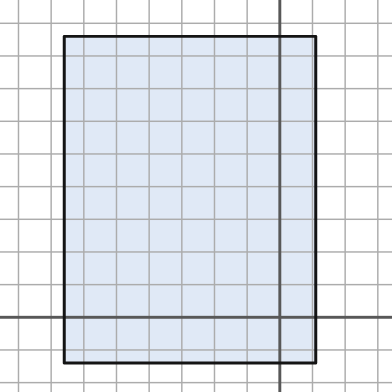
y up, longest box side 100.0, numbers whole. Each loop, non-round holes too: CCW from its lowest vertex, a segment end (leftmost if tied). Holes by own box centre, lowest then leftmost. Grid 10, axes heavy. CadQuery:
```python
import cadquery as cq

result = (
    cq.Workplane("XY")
    .moveTo(-66.0, -14.0)
    .lineTo(11.0, -14.0)
    .lineTo(11.0, 86.0)
    .lineTo(-66.0, 86.0)
    .close()
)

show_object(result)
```